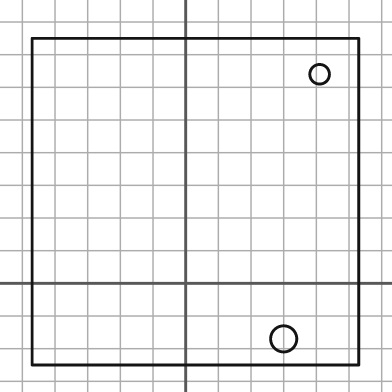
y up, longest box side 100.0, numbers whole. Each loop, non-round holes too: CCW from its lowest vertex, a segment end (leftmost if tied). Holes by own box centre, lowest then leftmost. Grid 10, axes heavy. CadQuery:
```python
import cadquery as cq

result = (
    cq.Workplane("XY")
    .moveTo(-47.0, -25.0)
    .lineTo(53.0, -25.0)
    .lineTo(53.0, 75.0)
    .lineTo(-47.0, 75.0)
    .close()
    .moveTo(30.0, -17.0)
    .circle(4.0)
    .moveTo(41.0, 64.0)
    .circle(3.0)
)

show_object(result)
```